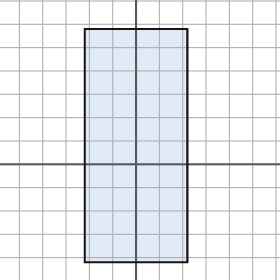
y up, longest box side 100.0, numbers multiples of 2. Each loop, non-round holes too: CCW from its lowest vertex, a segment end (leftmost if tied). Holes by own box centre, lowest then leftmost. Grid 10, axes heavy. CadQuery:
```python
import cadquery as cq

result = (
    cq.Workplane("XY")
    .moveTo(-22.0, -42.0)
    .lineTo(22.0, -42.0)
    .lineTo(22.0, 58.0)
    .lineTo(-22.0, 58.0)
    .close()
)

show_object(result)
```